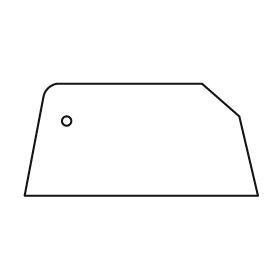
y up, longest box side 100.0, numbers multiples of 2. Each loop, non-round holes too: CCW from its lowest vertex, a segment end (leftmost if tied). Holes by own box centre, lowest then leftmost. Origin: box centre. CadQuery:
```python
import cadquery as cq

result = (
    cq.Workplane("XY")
    .moveTo(-50.0, -24.0)
    .lineTo(50.0, -24.0)
    .lineTo(42.0, 10.0)
    .lineTo(26.0, 24.0)
    .lineTo(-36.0, 24.0)
    .threePointArc((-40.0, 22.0), (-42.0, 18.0))
    .close()
    .moveTo(-32.0, 8.0)
    .circle(2.0)
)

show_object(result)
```